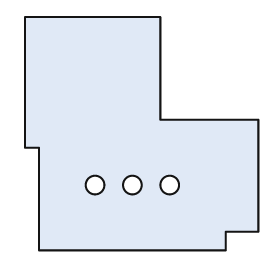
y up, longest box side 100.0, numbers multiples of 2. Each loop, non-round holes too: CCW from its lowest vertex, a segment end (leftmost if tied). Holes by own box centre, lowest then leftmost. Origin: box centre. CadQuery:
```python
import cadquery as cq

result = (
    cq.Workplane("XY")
    .moveTo(-44.0, -50.0)
    .lineTo(36.0, -50.0)
    .lineTo(36.0, -42.0)
    .lineTo(50.0, -42.0)
    .lineTo(50.0, 6.0)
    .lineTo(8.0, 6.0)
    .lineTo(8.0, 50.0)
    .lineTo(-50.0, 50.0)
    .lineTo(-50.0, -6.0)
    .lineTo(-44.0, -6.0)
    .close()
    .moveTo(-20.0, -22.0)
    .circle(4.0)
    .moveTo(-4.0, -22.0)
    .circle(4.0)
    .moveTo(12.0, -22.0)
    .circle(4.0)
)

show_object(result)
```